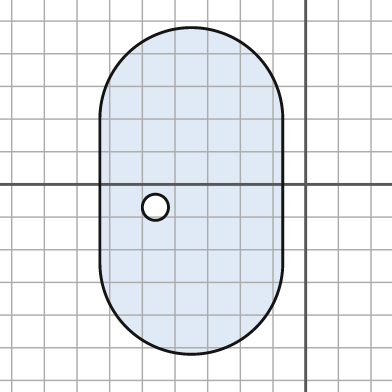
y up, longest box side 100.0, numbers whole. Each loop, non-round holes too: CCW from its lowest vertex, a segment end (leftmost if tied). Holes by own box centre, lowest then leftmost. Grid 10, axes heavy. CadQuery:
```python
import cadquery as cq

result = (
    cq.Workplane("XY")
    .moveTo(-63.0, -24.0)
    .threePointArc((-35.0, -52.0), (-7.0, -24.0))
    .lineTo(-7.0, 20.0)
    .threePointArc((-35.0, 48.0), (-63.0, 20.0))
    .close()
    .moveTo(-46.0, -7.0)
    .circle(4.0)
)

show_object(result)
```